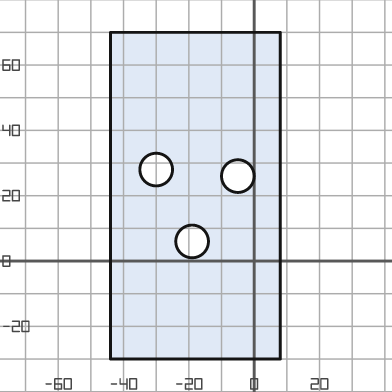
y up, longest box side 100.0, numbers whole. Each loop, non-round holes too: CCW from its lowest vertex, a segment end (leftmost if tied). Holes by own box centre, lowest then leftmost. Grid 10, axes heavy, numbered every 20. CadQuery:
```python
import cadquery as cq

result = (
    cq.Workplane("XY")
    .moveTo(-44.0, -30.0)
    .lineTo(8.0, -30.0)
    .lineTo(8.0, 70.0)
    .lineTo(-44.0, 70.0)
    .close()
    .moveTo(-19.0, 6.0)
    .circle(5.0)
    .moveTo(-5.0, 26.0)
    .circle(5.0)
    .moveTo(-30.0, 28.0)
    .circle(5.0)
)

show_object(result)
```